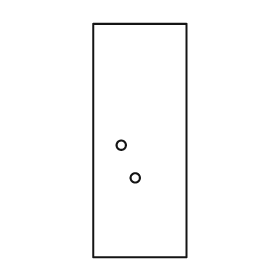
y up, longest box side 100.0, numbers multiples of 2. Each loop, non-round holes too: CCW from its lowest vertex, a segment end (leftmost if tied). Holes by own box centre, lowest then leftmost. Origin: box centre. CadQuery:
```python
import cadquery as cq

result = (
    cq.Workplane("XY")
    .moveTo(-20.0, -50.0)
    .lineTo(20.0, -50.0)
    .lineTo(20.0, 50.0)
    .lineTo(-20.0, 50.0)
    .close()
    .moveTo(-2.0, -16.0)
    .circle(2.0)
    .moveTo(-8.0, -2.0)
    .circle(2.0)
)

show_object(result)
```